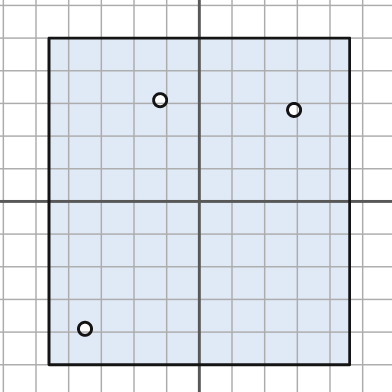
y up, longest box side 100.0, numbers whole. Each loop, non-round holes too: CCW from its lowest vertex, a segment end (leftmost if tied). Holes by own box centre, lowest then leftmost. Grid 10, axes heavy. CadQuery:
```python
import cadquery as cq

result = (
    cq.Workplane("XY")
    .moveTo(-46.0, -50.0)
    .lineTo(46.0, -50.0)
    .lineTo(46.0, 50.0)
    .lineTo(-46.0, 50.0)
    .close()
    .moveTo(-35.0, -39.0)
    .circle(2.0)
    .moveTo(29.0, 28.0)
    .circle(2.0)
    .moveTo(-12.0, 31.0)
    .circle(2.0)
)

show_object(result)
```